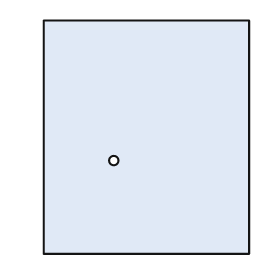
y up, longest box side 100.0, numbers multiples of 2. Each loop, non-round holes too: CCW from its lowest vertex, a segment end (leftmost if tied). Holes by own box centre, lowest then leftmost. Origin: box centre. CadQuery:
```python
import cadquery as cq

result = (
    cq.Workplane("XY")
    .moveTo(-44.0, -50.0)
    .lineTo(44.0, -50.0)
    .lineTo(44.0, 50.0)
    .lineTo(-44.0, 50.0)
    .close()
    .moveTo(-14.0, -10.0)
    .circle(2.0)
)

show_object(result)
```